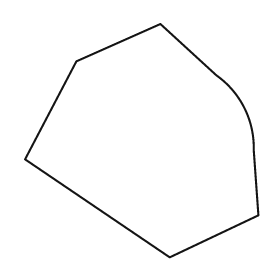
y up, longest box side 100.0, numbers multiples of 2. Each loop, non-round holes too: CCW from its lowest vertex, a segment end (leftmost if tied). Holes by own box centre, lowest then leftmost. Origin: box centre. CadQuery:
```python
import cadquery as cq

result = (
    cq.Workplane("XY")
    .moveTo(12.0, -50.0)
    .lineTo(50.0, -32.0)
    .lineTo(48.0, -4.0)
    .threePointArc((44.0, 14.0), (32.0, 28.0))
    .lineTo(8.0, 50.0)
    .lineTo(-28.0, 34.0)
    .lineTo(-50.0, -8.0)
    .close()
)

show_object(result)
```